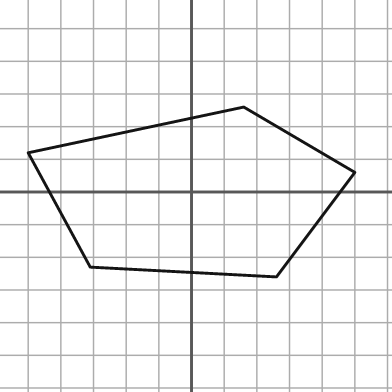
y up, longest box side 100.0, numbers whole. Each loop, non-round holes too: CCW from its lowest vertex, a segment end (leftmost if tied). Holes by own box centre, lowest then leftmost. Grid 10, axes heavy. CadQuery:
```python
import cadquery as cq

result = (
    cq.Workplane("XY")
    .moveTo(26.0, -26.0)
    .lineTo(50.0, 6.0)
    .lineTo(16.0, 26.0)
    .lineTo(-50.0, 12.0)
    .lineTo(-31.0, -23.0)
    .close()
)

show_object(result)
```